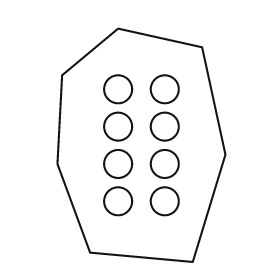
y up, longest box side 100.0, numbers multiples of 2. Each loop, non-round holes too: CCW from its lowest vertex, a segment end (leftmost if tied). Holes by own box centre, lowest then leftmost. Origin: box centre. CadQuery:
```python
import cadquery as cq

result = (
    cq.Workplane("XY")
    .moveTo(22.0, -50.0)
    .lineTo(36.0, -4.0)
    .lineTo(26.0, 42.0)
    .lineTo(-10.0, 50.0)
    .lineTo(-34.0, 30.0)
    .lineTo(-36.0, -8.0)
    .lineTo(-22.0, -46.0)
    .close()
    .moveTo(-10.0, -24.0)
    .circle(6.0)
    .moveTo(10.0, -24.0)
    .circle(6.0)
    .moveTo(-10.0, -8.0)
    .circle(6.0)
    .moveTo(10.0, -8.0)
    .circle(6.0)
    .moveTo(-10.0, 8.0)
    .circle(6.0)
    .moveTo(10.0, 8.0)
    .circle(6.0)
    .moveTo(-10.0, 24.0)
    .circle(6.0)
    .moveTo(10.0, 24.0)
    .circle(6.0)
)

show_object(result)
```